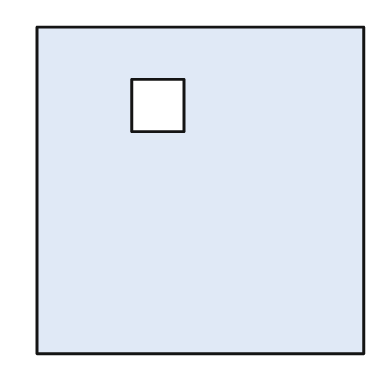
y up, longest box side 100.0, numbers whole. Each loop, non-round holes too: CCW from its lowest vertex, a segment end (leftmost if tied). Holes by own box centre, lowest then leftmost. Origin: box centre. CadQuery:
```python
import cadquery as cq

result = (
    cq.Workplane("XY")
    .moveTo(-50.0, -50.0)
    .lineTo(50.0, -50.0)
    .lineTo(50.0, 50.0)
    .lineTo(-50.0, 50.0)
    .close()
    .moveTo(-21.0, 18.0)
    .lineTo(-5.0, 18.0)
    .lineTo(-5.0, 34.0)
    .lineTo(-21.0, 34.0)
    .close()
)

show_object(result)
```